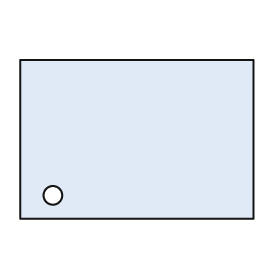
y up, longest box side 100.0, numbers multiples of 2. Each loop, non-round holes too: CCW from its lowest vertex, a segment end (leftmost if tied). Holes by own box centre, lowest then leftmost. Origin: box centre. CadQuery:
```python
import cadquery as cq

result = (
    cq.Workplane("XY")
    .moveTo(-50.0, -34.0)
    .lineTo(50.0, -34.0)
    .lineTo(50.0, 34.0)
    .lineTo(-50.0, 34.0)
    .close()
    .moveTo(-36.0, -24.0)
    .circle(4.0)
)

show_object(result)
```